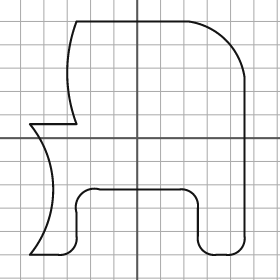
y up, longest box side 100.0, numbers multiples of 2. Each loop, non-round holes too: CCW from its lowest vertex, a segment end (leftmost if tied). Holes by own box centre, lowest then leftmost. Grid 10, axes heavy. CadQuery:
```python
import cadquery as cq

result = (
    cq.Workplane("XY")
    .moveTo(-46.0, -50.0)
    .lineTo(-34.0, -50.0)
    .threePointArc((-28.0, -48.0), (-26.0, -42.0))
    .lineTo(-26.0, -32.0)
    .threePointArc((-24.0, -24.0), (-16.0, -22.0))
    .lineTo(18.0, -22.0)
    .threePointArc((24.0, -24.0), (26.0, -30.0))
    .lineTo(26.0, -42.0)
    .threePointArc((28.0, -48.0), (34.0, -50.0))
    .lineTo(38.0, -50.0)
    .threePointArc((44.0, -48.0), (46.0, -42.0))
    .lineTo(46.0, 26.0)
    .threePointArc((38.0, 42.0), (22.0, 50.0))
    .lineTo(-26.0, 50.0)
    .threePointArc((-30.0, 28.0), (-26.0, 6.0))
    .lineTo(-46.0, 6.0)
    .threePointArc((-36.0, -22.0), (-46.0, -50.0))
    .close()
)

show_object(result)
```